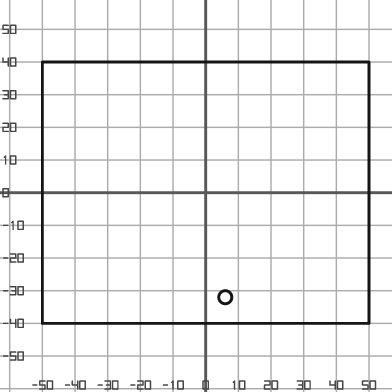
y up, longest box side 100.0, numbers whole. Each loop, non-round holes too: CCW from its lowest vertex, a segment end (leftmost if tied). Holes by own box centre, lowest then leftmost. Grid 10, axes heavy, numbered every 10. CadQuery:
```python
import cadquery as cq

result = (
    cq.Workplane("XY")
    .moveTo(-50.0, -40.0)
    .lineTo(50.0, -40.0)
    .lineTo(50.0, 40.0)
    .lineTo(-50.0, 40.0)
    .close()
    .moveTo(6.0, -32.0)
    .circle(2.0)
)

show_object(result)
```